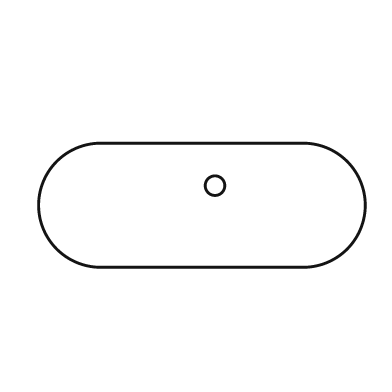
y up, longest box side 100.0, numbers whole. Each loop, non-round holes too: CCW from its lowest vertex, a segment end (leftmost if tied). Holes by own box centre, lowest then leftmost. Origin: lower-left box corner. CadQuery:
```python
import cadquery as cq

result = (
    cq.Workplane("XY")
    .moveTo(19.0, 0.0)
    .lineTo(81.0, 0.0)
    .threePointArc((100.0, 19.0), (81.0, 38.0))
    .lineTo(19.0, 38.0)
    .threePointArc((0.0, 19.0), (19.0, 0.0))
    .close()
    .moveTo(54.0, 25.0)
    .circle(3.0)
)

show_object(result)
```